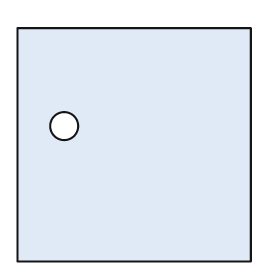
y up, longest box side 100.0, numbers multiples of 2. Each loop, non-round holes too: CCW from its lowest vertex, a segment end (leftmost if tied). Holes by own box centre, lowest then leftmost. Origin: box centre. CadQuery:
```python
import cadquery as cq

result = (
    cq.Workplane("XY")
    .moveTo(-50.0, -50.0)
    .lineTo(50.0, -50.0)
    .lineTo(50.0, 50.0)
    .lineTo(-50.0, 50.0)
    .close()
    .moveTo(-30.0, 8.0)
    .circle(6.0)
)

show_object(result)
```